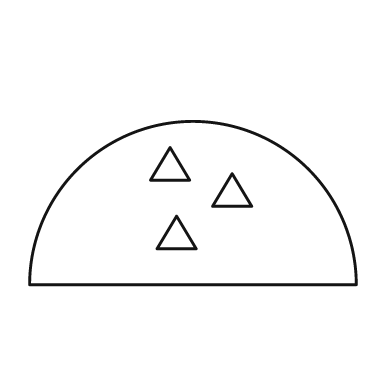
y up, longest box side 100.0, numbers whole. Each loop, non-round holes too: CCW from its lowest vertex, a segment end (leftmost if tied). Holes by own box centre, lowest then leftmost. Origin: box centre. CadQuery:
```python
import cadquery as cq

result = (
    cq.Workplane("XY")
    .moveTo(-50.0, -25.0)
    .lineTo(50.0, -25.0)
    .threePointArc((0.0, 25.0), (-50.0, -25.0))
    .close()
    .moveTo(-11.0, -14.0)
    .lineTo(1.0, -14.0)
    .lineTo(-5.0, -4.0)
    .close()
    .moveTo(6.0, -1.0)
    .lineTo(18.0, -1.0)
    .lineTo(12.0, 9.0)
    .close()
    .moveTo(-13.0, 7.0)
    .lineTo(-1.0, 7.0)
    .lineTo(-7.0, 17.0)
    .close()
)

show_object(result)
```